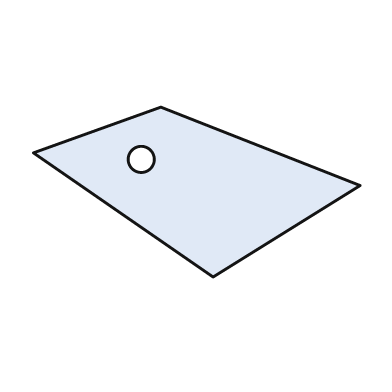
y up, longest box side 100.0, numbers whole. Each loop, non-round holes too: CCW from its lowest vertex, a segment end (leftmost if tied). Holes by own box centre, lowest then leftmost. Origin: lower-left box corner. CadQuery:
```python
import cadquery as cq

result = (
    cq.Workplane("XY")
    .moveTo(55.0, 0.0)
    .lineTo(100.0, 28.0)
    .lineTo(39.0, 52.0)
    .lineTo(0.0, 38.0)
    .close()
    .moveTo(33.0, 36.0)
    .circle(4.0)
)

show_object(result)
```